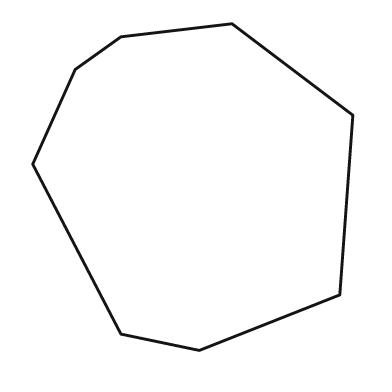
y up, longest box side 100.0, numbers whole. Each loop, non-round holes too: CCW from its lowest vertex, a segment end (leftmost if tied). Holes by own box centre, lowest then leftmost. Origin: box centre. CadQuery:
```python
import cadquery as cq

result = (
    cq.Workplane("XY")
    .moveTo(2.0, -50.0)
    .lineTo(45.0, -33.0)
    .lineTo(49.0, 22.0)
    .lineTo(12.0, 50.0)
    .lineTo(-22.0, 46.0)
    .lineTo(-36.0, 36.0)
    .lineTo(-49.0, 7.0)
    .lineTo(-22.0, -45.0)
    .close()
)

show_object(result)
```